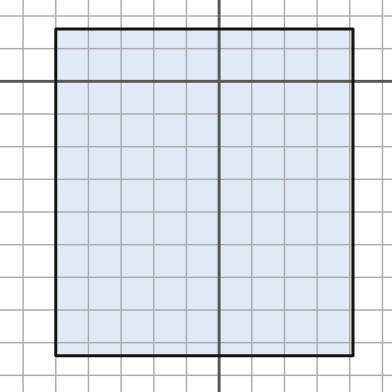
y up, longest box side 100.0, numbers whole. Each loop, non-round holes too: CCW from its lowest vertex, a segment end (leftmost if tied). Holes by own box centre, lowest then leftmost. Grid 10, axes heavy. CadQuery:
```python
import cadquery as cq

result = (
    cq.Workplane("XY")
    .moveTo(-50.0, -84.0)
    .lineTo(41.0, -84.0)
    .lineTo(41.0, 16.0)
    .lineTo(-50.0, 16.0)
    .close()
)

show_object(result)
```